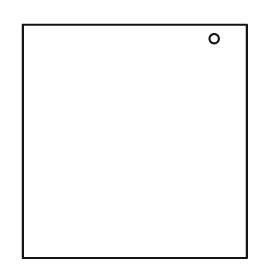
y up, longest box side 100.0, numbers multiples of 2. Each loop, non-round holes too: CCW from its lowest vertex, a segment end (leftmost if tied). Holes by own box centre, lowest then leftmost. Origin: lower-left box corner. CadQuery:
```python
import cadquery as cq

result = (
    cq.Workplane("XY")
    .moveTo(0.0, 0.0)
    .lineTo(96.0, 0.0)
    .lineTo(96.0, 100.0)
    .lineTo(0.0, 100.0)
    .close()
    .moveTo(82.0, 94.0)
    .circle(2.0)
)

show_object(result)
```